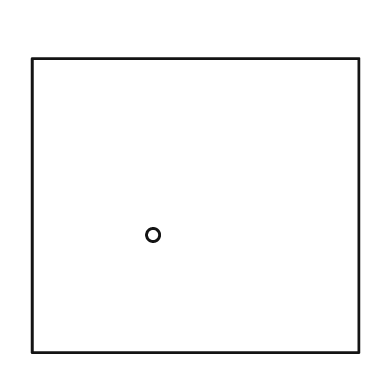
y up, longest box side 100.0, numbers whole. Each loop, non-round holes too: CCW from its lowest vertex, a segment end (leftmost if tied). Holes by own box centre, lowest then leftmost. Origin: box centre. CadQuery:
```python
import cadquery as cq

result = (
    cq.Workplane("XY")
    .moveTo(-50.0, -45.0)
    .lineTo(50.0, -45.0)
    .lineTo(50.0, 45.0)
    .lineTo(-50.0, 45.0)
    .close()
    .moveTo(-13.0, -9.0)
    .circle(2.0)
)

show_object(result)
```